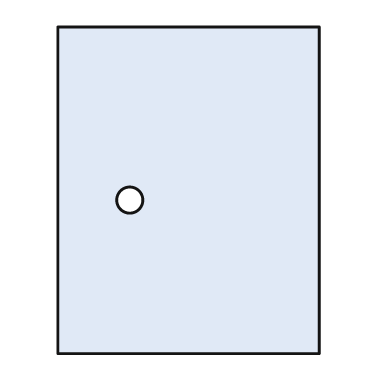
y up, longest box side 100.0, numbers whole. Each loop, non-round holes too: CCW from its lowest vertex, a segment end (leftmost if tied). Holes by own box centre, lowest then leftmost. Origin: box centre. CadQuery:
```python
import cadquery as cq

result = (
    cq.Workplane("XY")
    .moveTo(-40.0, -50.0)
    .lineTo(40.0, -50.0)
    .lineTo(40.0, 50.0)
    .lineTo(-40.0, 50.0)
    .close()
    .moveTo(-18.0, -3.0)
    .circle(4.0)
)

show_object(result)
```